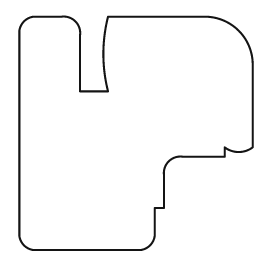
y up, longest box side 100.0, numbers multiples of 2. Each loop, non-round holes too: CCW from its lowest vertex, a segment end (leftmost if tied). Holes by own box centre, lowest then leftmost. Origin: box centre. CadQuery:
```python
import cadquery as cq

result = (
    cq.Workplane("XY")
    .moveTo(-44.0, -50.0)
    .lineTo(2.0, -50.0)
    .threePointArc((6.0, -48.0), (8.0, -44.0))
    .lineTo(8.0, -32.0)
    .lineTo(12.0, -32.0)
    .lineTo(12.0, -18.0)
    .threePointArc((14.0, -12.0), (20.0, -10.0))
    .lineTo(38.0, -10.0)
    .lineTo(38.0, -6.0)
    .threePointArc((44.0, -8.0), (50.0, -6.0))
    .lineTo(50.0, 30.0)
    .threePointArc((44.0, 44.0), (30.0, 50.0))
    .lineTo(-12.0, 50.0)
    .threePointArc((-14.0, 34.0), (-12.0, 18.0))
    .lineTo(-24.0, 18.0)
    .lineTo(-24.0, 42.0)
    .threePointArc((-26.0, 48.0), (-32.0, 50.0))
    .lineTo(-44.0, 50.0)
    .threePointArc((-48.0, 48.0), (-50.0, 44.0))
    .lineTo(-50.0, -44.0)
    .threePointArc((-48.0, -48.0), (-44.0, -50.0))
    .close()
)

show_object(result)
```